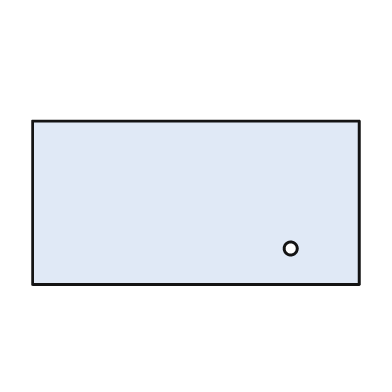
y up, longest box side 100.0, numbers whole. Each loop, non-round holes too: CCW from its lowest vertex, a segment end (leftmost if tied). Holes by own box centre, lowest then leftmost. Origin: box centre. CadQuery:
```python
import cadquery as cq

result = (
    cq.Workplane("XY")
    .moveTo(-50.0, -25.0)
    .lineTo(50.0, -25.0)
    .lineTo(50.0, 25.0)
    .lineTo(-50.0, 25.0)
    .close()
    .moveTo(29.0, -14.0)
    .circle(2.0)
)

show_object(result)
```